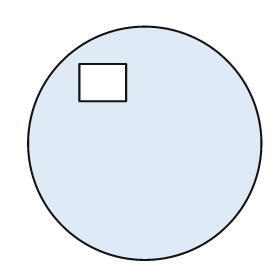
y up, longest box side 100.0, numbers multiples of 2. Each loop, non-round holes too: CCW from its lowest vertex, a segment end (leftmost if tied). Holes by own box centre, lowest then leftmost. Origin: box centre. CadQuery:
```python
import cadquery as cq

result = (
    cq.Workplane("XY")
    .moveTo(0.0, 0.0)
    .circle(50.0)
    .moveTo(-28.0, 18.0)
    .lineTo(-8.0, 18.0)
    .lineTo(-8.0, 34.0)
    .lineTo(-28.0, 34.0)
    .close()
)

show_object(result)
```